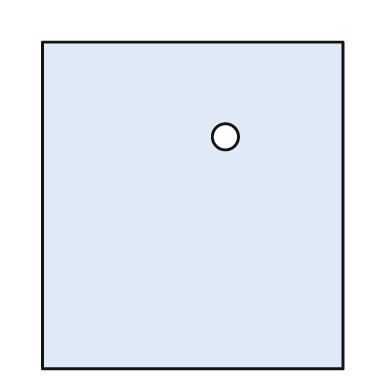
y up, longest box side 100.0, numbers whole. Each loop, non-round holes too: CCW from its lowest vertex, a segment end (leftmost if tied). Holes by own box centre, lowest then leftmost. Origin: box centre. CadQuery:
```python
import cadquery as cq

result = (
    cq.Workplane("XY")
    .moveTo(-46.0, -50.0)
    .lineTo(46.0, -50.0)
    .lineTo(46.0, 50.0)
    .lineTo(-46.0, 50.0)
    .close()
    .moveTo(10.0, 21.0)
    .circle(4.0)
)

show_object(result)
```